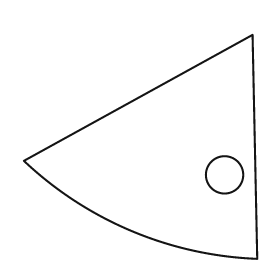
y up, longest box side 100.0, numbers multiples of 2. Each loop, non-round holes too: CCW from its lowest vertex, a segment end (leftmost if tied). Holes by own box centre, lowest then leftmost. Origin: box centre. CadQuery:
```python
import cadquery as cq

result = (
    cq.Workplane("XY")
    .moveTo(50.0, -48.0)
    .lineTo(48.0, 48.0)
    .lineTo(-50.0, -6.0)
    .threePointArc((-4.0, -36.0), (50.0, -48.0))
    .close()
    .moveTo(36.0, -12.0)
    .circle(8.0)
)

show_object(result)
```